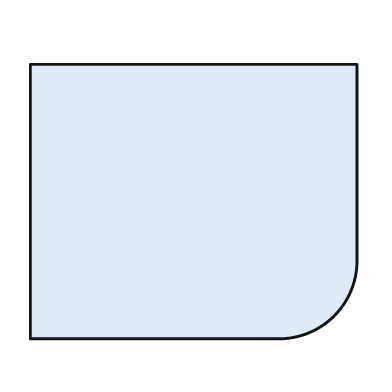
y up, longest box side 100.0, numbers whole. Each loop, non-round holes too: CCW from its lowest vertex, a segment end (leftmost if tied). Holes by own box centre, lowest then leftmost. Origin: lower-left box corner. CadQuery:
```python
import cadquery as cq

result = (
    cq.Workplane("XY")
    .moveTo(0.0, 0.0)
    .lineTo(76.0, 0.0)
    .threePointArc((93.0, 7.0), (100.0, 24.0))
    .lineTo(100.0, 84.0)
    .lineTo(0.0, 84.0)
    .close()
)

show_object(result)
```